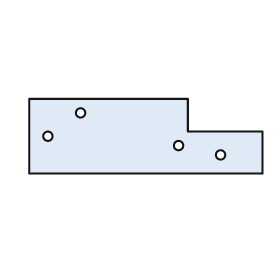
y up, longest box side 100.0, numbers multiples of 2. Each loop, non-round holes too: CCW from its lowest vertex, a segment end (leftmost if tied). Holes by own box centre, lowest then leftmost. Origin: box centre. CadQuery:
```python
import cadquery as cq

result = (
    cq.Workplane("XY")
    .moveTo(-50.0, -16.0)
    .lineTo(50.0, -16.0)
    .lineTo(50.0, 2.0)
    .lineTo(18.0, 2.0)
    .lineTo(18.0, 16.0)
    .lineTo(-50.0, 16.0)
    .close()
    .moveTo(32.0, -8.0)
    .circle(2.0)
    .moveTo(14.0, -4.0)
    .circle(2.0)
    .moveTo(-42.0, 0.0)
    .circle(2.0)
    .moveTo(-28.0, 10.0)
    .circle(2.0)
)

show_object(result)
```